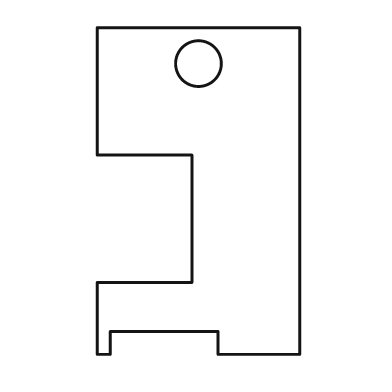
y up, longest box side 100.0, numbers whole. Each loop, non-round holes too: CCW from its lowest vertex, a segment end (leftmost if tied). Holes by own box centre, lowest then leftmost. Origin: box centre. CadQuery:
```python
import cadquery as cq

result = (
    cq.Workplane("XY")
    .moveTo(-31.0, -50.0)
    .lineTo(-27.0, -50.0)
    .lineTo(-27.0, -43.0)
    .lineTo(6.0, -43.0)
    .lineTo(6.0, -50.0)
    .lineTo(31.0, -50.0)
    .lineTo(31.0, 50.0)
    .lineTo(-31.0, 50.0)
    .lineTo(-31.0, 11.0)
    .lineTo(-2.0, 11.0)
    .lineTo(-2.0, -28.0)
    .lineTo(-31.0, -28.0)
    .close()
    .moveTo(0.0, 39.0)
    .circle(7.0)
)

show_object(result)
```